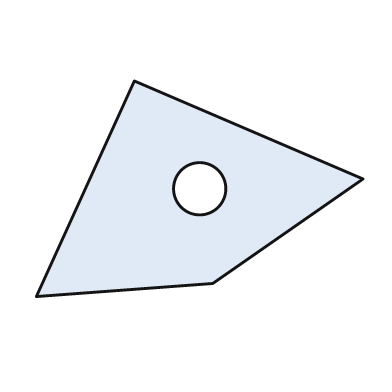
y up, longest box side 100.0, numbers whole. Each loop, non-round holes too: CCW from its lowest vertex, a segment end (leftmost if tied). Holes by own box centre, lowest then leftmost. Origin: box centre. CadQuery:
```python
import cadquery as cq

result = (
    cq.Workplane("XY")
    .moveTo(-50.0, -33.0)
    .lineTo(4.0, -29.0)
    .lineTo(50.0, 3.0)
    .lineTo(-20.0, 33.0)
    .close()
    .moveTo(0.0, 0.0)
    .circle(8.0)
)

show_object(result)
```